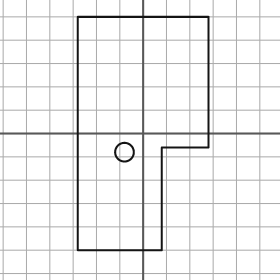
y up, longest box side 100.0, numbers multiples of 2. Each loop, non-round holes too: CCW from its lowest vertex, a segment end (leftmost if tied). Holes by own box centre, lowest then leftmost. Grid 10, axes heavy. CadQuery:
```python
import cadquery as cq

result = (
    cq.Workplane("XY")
    .moveTo(-28.0, -50.0)
    .lineTo(8.0, -50.0)
    .lineTo(8.0, -6.0)
    .lineTo(28.0, -6.0)
    .lineTo(28.0, 50.0)
    .lineTo(-28.0, 50.0)
    .close()
    .moveTo(-8.0, -8.0)
    .circle(4.0)
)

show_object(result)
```